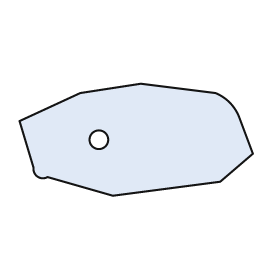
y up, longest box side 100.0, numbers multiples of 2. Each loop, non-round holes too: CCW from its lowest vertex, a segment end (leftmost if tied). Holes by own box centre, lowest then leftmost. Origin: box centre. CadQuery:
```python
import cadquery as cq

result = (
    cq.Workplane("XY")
    .moveTo(-10.0, -24.0)
    .lineTo(36.0, -18.0)
    .lineTo(50.0, -6.0)
    .lineTo(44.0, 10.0)
    .threePointArc((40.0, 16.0), (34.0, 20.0))
    .lineTo(2.0, 24.0)
    .lineTo(-24.0, 20.0)
    .lineTo(-50.0, 8.0)
    .lineTo(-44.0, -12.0)
    .threePointArc((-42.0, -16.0), (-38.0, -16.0))
    .close()
    .moveTo(-16.0, 0.0)
    .circle(4.0)
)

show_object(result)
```